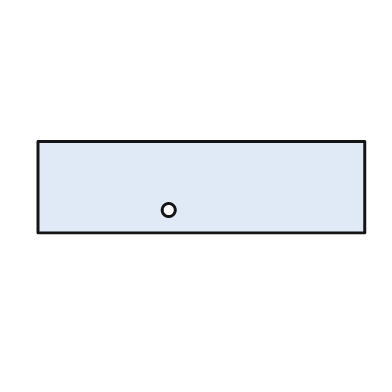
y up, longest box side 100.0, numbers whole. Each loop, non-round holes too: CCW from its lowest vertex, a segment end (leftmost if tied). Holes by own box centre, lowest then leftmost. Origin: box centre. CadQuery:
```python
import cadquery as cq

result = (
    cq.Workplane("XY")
    .moveTo(-50.0, -14.0)
    .lineTo(50.0, -14.0)
    .lineTo(50.0, 14.0)
    .lineTo(-50.0, 14.0)
    .close()
    .moveTo(-10.0, -7.0)
    .circle(2.0)
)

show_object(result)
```